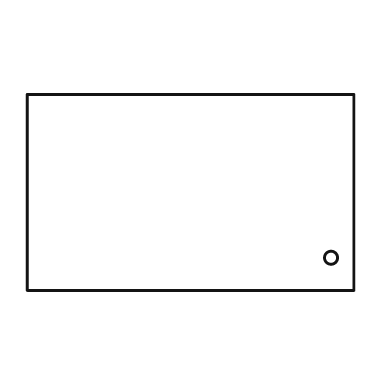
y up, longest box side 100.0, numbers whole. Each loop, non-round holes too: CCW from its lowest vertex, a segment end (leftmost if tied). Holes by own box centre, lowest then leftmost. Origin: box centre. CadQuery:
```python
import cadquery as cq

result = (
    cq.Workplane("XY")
    .moveTo(-50.0, -30.0)
    .lineTo(50.0, -30.0)
    .lineTo(50.0, 30.0)
    .lineTo(-50.0, 30.0)
    .close()
    .moveTo(43.0, -20.0)
    .circle(2.0)
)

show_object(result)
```